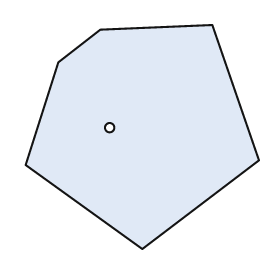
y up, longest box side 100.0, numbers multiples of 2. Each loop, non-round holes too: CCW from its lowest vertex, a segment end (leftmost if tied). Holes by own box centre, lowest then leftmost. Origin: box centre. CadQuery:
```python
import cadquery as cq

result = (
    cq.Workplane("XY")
    .moveTo(0.0, -48.0)
    .lineTo(50.0, -10.0)
    .lineTo(30.0, 48.0)
    .lineTo(-18.0, 46.0)
    .lineTo(-36.0, 32.0)
    .lineTo(-50.0, -12.0)
    .close()
    .moveTo(-14.0, 4.0)
    .circle(2.0)
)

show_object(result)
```